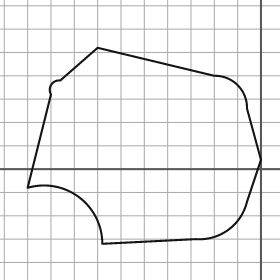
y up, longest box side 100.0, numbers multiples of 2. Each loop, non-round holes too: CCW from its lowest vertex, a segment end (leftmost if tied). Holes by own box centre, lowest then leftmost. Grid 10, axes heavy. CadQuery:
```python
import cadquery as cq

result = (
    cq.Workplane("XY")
    .moveTo(-68.0, -32.0)
    .lineTo(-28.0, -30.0)
    .threePointArc((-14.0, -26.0), (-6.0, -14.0))
    .lineTo(0.0, 4.0)
    .lineTo(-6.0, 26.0)
    .threePointArc((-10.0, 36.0), (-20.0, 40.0))
    .lineTo(-70.0, 52.0)
    .lineTo(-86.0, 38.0)
    .threePointArc((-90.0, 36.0), (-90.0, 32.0))
    .lineTo(-100.0, -8.0)
    .threePointArc((-78.0, -12.0), (-68.0, -32.0))
    .close()
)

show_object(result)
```